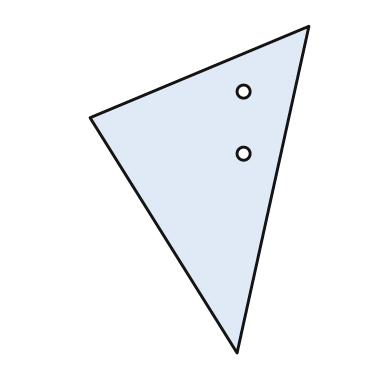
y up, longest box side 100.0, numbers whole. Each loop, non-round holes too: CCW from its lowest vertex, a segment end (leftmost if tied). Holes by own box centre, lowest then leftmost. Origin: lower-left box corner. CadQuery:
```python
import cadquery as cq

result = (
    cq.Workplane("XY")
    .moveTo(45.0, 0.0)
    .lineTo(67.0, 100.0)
    .lineTo(0.0, 72.0)
    .close()
    .moveTo(47.0, 61.0)
    .circle(2.0)
    .moveTo(47.0, 80.0)
    .circle(2.0)
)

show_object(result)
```